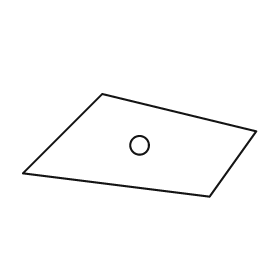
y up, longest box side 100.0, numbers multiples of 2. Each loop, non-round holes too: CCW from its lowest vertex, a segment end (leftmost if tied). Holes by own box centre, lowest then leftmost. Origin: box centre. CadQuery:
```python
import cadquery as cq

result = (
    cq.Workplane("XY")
    .moveTo(30.0, -22.0)
    .lineTo(50.0, 6.0)
    .lineTo(-16.0, 22.0)
    .lineTo(-50.0, -12.0)
    .close()
    .moveTo(0.0, 0.0)
    .circle(4.0)
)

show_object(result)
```